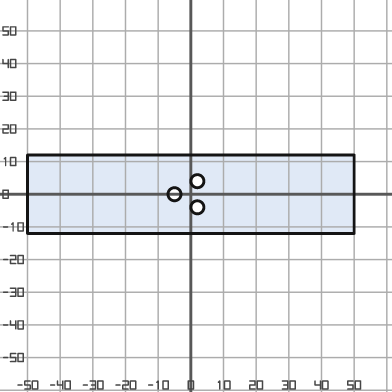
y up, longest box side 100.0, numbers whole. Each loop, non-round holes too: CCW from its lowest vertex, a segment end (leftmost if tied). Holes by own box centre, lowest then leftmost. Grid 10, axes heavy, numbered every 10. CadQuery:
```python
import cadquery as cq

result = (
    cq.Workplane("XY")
    .moveTo(-50.0, -12.0)
    .lineTo(50.0, -12.0)
    .lineTo(50.0, 12.0)
    .lineTo(-50.0, 12.0)
    .close()
    .moveTo(2.0, -4.0)
    .circle(2.0)
    .moveTo(-5.0, 0.0)
    .circle(2.0)
    .moveTo(2.0, 4.0)
    .circle(2.0)
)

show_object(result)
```